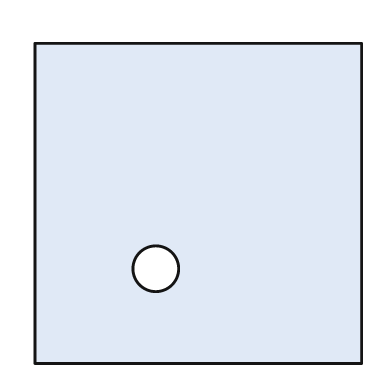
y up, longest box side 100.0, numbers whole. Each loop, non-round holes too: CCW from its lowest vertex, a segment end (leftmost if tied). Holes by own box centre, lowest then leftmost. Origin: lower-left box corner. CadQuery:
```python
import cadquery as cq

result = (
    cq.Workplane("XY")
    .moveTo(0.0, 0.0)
    .lineTo(100.0, 0.0)
    .lineTo(100.0, 98.0)
    .lineTo(0.0, 98.0)
    .close()
    .moveTo(37.0, 29.0)
    .circle(7.0)
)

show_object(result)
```